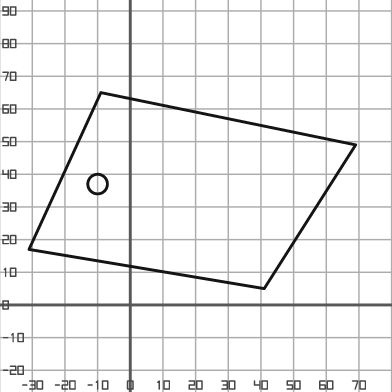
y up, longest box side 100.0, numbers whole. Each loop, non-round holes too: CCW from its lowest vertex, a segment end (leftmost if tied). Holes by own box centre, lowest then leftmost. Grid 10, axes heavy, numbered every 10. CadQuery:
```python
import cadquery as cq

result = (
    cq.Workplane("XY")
    .moveTo(41.0, 5.0)
    .lineTo(69.0, 49.0)
    .lineTo(-9.0, 65.0)
    .lineTo(-31.0, 17.0)
    .close()
    .moveTo(-10.0, 37.0)
    .circle(3.0)
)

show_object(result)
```